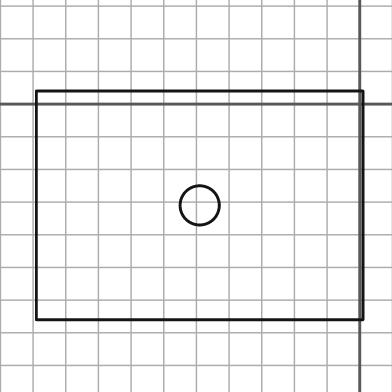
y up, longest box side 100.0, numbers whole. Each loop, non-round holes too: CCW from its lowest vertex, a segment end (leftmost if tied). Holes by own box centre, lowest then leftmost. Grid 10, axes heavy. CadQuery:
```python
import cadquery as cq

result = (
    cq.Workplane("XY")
    .moveTo(-99.0, -66.0)
    .lineTo(1.0, -66.0)
    .lineTo(1.0, 4.0)
    .lineTo(-99.0, 4.0)
    .close()
    .moveTo(-49.0, -31.0)
    .circle(6.0)
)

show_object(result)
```